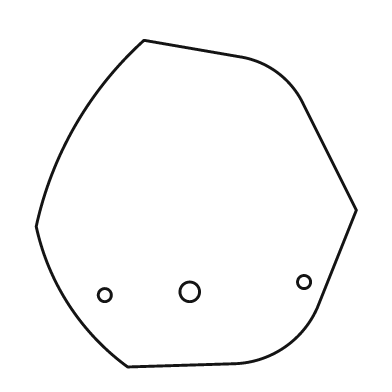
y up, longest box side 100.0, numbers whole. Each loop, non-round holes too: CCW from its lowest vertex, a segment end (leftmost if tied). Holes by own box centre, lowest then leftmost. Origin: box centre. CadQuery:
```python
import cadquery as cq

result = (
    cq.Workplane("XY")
    .moveTo(-21.0, -50.0)
    .lineTo(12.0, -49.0)
    .threePointArc((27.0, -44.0), (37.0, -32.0))
    .lineTo(49.0, -2.0)
    .lineTo(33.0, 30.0)
    .threePointArc((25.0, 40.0), (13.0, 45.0))
    .lineTo(-16.0, 50.0)
    .threePointArc((-37.0, 24.0), (-49.0, -7.0))
    .threePointArc((-39.0, -31.0), (-21.0, -50.0))
    .close()
    .moveTo(-28.0, -28.0)
    .circle(2.0)
    .moveTo(-2.0, -27.0)
    .circle(3.0)
    .moveTo(33.0, -24.0)
    .circle(2.0)
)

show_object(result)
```